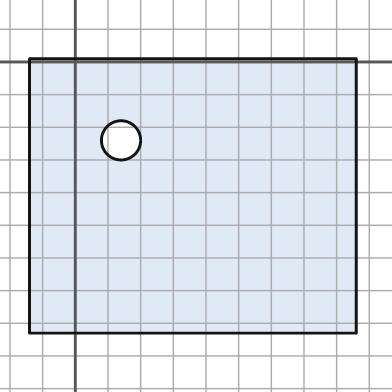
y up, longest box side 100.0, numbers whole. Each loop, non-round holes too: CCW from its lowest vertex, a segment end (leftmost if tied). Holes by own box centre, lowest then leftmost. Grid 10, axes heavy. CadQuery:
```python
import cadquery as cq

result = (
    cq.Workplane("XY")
    .moveTo(-14.0, -83.0)
    .lineTo(86.0, -83.0)
    .lineTo(86.0, 1.0)
    .lineTo(-14.0, 1.0)
    .close()
    .moveTo(14.0, -24.0)
    .circle(6.0)
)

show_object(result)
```